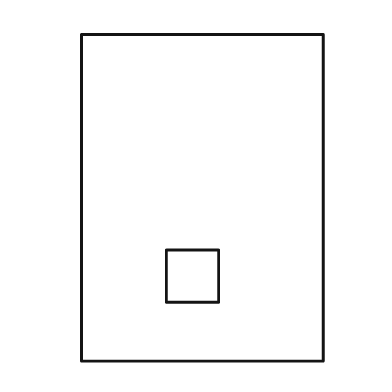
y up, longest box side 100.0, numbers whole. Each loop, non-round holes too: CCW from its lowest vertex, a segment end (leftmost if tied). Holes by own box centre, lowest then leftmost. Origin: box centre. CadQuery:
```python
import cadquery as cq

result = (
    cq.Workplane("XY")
    .moveTo(-37.0, -50.0)
    .lineTo(37.0, -50.0)
    .lineTo(37.0, 50.0)
    .lineTo(-37.0, 50.0)
    .close()
    .moveTo(-11.0, -32.0)
    .lineTo(5.0, -32.0)
    .lineTo(5.0, -16.0)
    .lineTo(-11.0, -16.0)
    .close()
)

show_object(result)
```